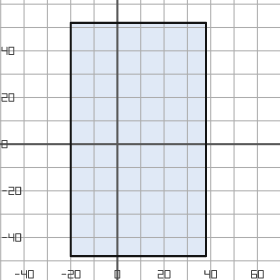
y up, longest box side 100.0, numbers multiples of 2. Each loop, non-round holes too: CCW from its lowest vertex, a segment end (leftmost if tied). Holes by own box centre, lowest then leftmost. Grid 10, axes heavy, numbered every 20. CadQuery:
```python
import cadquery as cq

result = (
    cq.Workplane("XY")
    .moveTo(-20.0, -48.0)
    .lineTo(38.0, -48.0)
    .lineTo(38.0, 52.0)
    .lineTo(-20.0, 52.0)
    .close()
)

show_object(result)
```